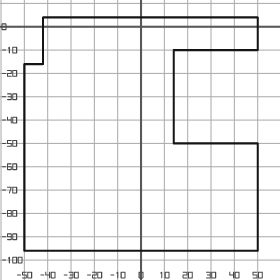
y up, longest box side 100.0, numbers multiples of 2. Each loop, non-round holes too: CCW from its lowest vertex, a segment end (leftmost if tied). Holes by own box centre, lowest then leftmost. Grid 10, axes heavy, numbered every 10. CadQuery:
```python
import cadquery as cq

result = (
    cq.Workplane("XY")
    .moveTo(-50.0, -96.0)
    .lineTo(50.0, -96.0)
    .lineTo(50.0, -50.0)
    .lineTo(14.0, -50.0)
    .lineTo(14.0, -10.0)
    .lineTo(50.0, -10.0)
    .lineTo(50.0, 4.0)
    .lineTo(-42.0, 4.0)
    .lineTo(-42.0, -16.0)
    .lineTo(-50.0, -16.0)
    .close()
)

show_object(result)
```